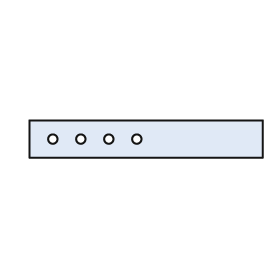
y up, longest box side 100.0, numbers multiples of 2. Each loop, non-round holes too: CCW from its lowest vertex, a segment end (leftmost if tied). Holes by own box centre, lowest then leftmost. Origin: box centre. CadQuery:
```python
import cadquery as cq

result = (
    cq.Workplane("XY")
    .moveTo(-50.0, -8.0)
    .lineTo(50.0, -8.0)
    .lineTo(50.0, 8.0)
    .lineTo(-50.0, 8.0)
    .close()
    .moveTo(-40.0, 0.0)
    .circle(2.0)
    .moveTo(-28.0, 0.0)
    .circle(2.0)
    .moveTo(-16.0, 0.0)
    .circle(2.0)
    .moveTo(-4.0, 0.0)
    .circle(2.0)
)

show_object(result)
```